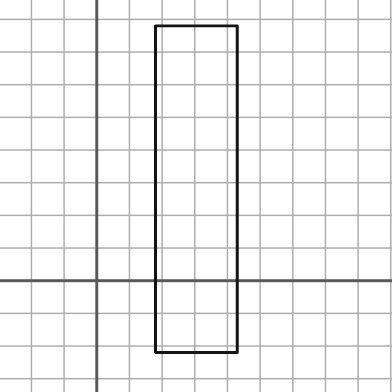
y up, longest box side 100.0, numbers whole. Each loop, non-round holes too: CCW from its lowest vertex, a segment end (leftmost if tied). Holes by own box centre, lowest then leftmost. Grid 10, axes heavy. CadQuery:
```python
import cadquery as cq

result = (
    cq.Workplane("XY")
    .moveTo(18.0, -22.0)
    .lineTo(43.0, -22.0)
    .lineTo(43.0, 78.0)
    .lineTo(18.0, 78.0)
    .close()
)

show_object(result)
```